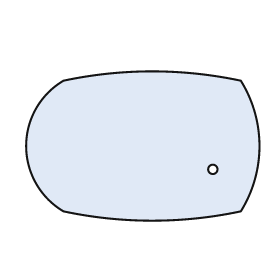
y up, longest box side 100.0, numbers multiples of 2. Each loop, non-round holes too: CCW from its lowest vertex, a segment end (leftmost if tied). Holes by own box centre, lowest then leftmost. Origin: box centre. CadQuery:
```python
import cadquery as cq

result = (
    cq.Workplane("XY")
    .moveTo(-34.0, -28.0)
    .threePointArc((4.0, -32.0), (42.0, -28.0))
    .threePointArc((50.0, 0.0), (42.0, 28.0))
    .threePointArc((4.0, 32.0), (-34.0, 28.0))
    .threePointArc((-50.0, 0.0), (-34.0, -28.0))
    .close()
    .moveTo(30.0, -10.0)
    .circle(2.0)
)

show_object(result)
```